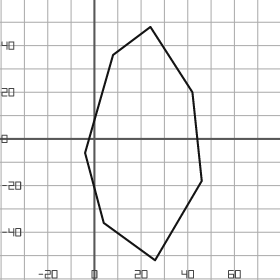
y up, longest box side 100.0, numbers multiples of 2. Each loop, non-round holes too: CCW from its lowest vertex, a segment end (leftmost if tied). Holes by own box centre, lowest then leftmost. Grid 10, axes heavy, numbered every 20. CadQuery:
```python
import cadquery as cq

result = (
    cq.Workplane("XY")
    .moveTo(26.0, -52.0)
    .lineTo(46.0, -18.0)
    .lineTo(42.0, 20.0)
    .lineTo(24.0, 48.0)
    .lineTo(8.0, 36.0)
    .lineTo(-4.0, -6.0)
    .lineTo(4.0, -36.0)
    .close()
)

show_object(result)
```